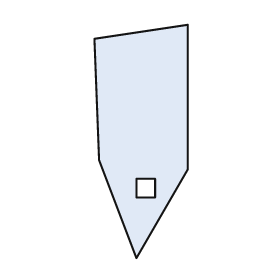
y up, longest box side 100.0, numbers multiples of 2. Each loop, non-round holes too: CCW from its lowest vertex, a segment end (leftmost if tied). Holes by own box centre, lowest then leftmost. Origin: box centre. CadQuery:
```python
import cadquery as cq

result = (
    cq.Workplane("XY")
    .moveTo(-2.0, -50.0)
    .lineTo(20.0, -12.0)
    .lineTo(20.0, 50.0)
    .lineTo(-20.0, 44.0)
    .lineTo(-18.0, -8.0)
    .close()
    .moveTo(-2.0, -24.0)
    .lineTo(6.0, -24.0)
    .lineTo(6.0, -16.0)
    .lineTo(-2.0, -16.0)
    .close()
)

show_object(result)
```